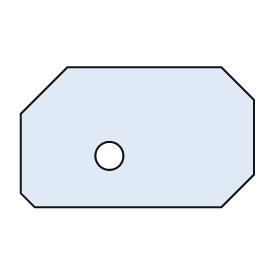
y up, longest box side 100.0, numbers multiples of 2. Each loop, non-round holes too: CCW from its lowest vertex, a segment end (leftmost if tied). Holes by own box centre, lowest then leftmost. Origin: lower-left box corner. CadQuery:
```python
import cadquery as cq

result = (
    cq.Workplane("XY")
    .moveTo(6.0, 0.0)
    .lineTo(86.0, 0.0)
    .lineTo(100.0, 14.0)
    .lineTo(100.0, 46.0)
    .lineTo(86.0, 60.0)
    .lineTo(20.0, 60.0)
    .lineTo(0.0, 40.0)
    .lineTo(0.0, 6.0)
    .close()
    .moveTo(38.0, 22.0)
    .circle(6.0)
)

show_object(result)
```